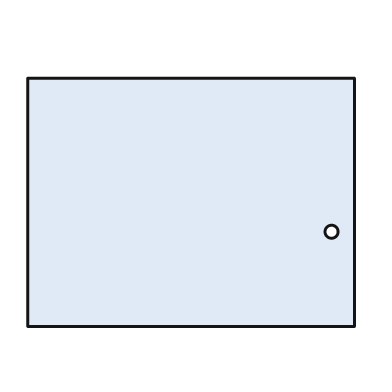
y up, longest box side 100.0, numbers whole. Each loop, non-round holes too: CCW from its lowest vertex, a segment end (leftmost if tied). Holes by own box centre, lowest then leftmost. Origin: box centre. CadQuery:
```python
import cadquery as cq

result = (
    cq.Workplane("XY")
    .moveTo(-50.0, -38.0)
    .lineTo(50.0, -38.0)
    .lineTo(50.0, 38.0)
    .lineTo(-50.0, 38.0)
    .close()
    .moveTo(43.0, -9.0)
    .circle(2.0)
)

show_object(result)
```